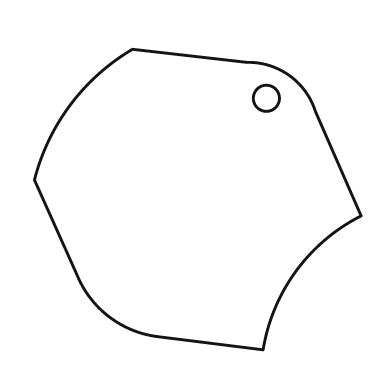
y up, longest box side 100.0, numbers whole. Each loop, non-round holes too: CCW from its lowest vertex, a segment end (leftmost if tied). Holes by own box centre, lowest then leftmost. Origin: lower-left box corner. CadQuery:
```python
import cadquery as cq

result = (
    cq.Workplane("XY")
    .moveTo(70.0, 0.0)
    .threePointArc((80.0, 24.0), (100.0, 41.0))
    .lineTo(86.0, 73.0)
    .threePointArc((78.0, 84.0), (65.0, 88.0))
    .lineTo(30.0, 92.0)
    .threePointArc((11.0, 75.0), (0.0, 52.0))
    .lineTo(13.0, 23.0)
    .threePointArc((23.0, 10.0), (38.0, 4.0))
    .close()
    .moveTo(71.0, 77.0)
    .circle(4.0)
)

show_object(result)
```